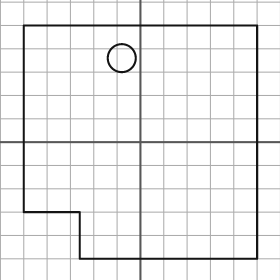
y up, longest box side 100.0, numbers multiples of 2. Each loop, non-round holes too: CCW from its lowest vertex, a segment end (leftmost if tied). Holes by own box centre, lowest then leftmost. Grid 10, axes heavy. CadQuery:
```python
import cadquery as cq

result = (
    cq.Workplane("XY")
    .moveTo(-26.0, -50.0)
    .lineTo(50.0, -50.0)
    .lineTo(50.0, 50.0)
    .lineTo(-50.0, 50.0)
    .lineTo(-50.0, -30.0)
    .lineTo(-26.0, -30.0)
    .close()
    .moveTo(-8.0, 36.0)
    .circle(6.0)
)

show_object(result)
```